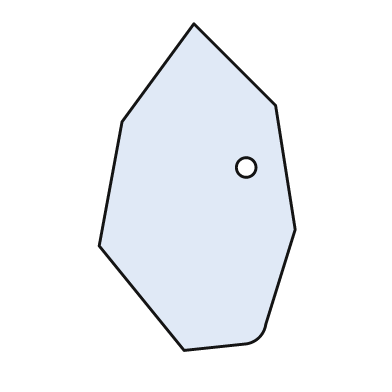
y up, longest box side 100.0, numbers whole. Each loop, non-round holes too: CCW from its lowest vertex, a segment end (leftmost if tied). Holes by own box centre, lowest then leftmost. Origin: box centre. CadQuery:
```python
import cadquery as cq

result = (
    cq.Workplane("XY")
    .moveTo(-4.0, -50.0)
    .lineTo(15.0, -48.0)
    .threePointArc((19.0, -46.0), (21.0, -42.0))
    .lineTo(30.0, -13.0)
    .lineTo(24.0, 25.0)
    .lineTo(-1.0, 50.0)
    .lineTo(-23.0, 20.0)
    .lineTo(-30.0, -18.0)
    .close()
    .moveTo(15.0, 6.0)
    .circle(3.0)
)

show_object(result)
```